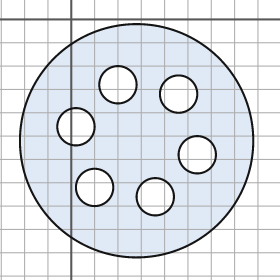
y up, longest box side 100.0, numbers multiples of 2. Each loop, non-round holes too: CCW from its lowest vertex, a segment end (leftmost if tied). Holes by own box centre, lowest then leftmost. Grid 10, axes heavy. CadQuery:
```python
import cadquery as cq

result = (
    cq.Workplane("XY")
    .moveTo(28.0, -52.0)
    .circle(50.0)
    .moveTo(36.0, -76.0)
    .circle(8.0)
    .moveTo(10.0, -72.0)
    .circle(8.0)
    .moveTo(54.0, -58.0)
    .circle(8.0)
    .moveTo(2.0, -46.0)
    .circle(8.0)
    .moveTo(46.0, -32.0)
    .circle(8.0)
    .moveTo(20.0, -28.0)
    .circle(8.0)
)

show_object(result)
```